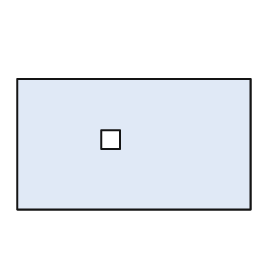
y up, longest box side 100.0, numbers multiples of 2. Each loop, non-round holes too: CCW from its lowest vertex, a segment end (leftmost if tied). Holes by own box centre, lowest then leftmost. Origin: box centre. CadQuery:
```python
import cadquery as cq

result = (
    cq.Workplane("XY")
    .moveTo(-50.0, -28.0)
    .lineTo(50.0, -28.0)
    .lineTo(50.0, 28.0)
    .lineTo(-50.0, 28.0)
    .close()
    .moveTo(-14.0, -2.0)
    .lineTo(-6.0, -2.0)
    .lineTo(-6.0, 6.0)
    .lineTo(-14.0, 6.0)
    .close()
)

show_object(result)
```